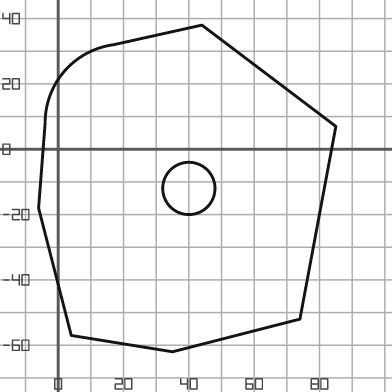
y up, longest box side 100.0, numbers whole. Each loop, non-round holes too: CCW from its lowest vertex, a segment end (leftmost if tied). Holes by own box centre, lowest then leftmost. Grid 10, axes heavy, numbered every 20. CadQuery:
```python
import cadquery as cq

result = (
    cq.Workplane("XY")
    .moveTo(35.0, -62.0)
    .lineTo(74.0, -52.0)
    .lineTo(85.0, 7.0)
    .lineTo(44.0, 38.0)
    .lineTo(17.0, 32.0)
    .threePointArc((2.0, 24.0), (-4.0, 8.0))
    .lineTo(-6.0, -18.0)
    .lineTo(4.0, -57.0)
    .close()
    .moveTo(40.0, -12.0)
    .circle(8.0)
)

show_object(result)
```